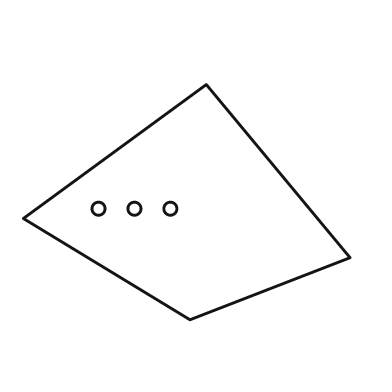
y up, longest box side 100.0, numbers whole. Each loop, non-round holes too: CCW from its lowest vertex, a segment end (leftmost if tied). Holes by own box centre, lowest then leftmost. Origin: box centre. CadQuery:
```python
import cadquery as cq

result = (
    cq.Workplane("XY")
    .moveTo(1.0, -36.0)
    .lineTo(50.0, -17.0)
    .lineTo(6.0, 36.0)
    .lineTo(-50.0, -5.0)
    .close()
    .moveTo(-27.0, -2.0)
    .circle(2.0)
    .moveTo(-16.0, -2.0)
    .circle(2.0)
    .moveTo(-5.0, -2.0)
    .circle(2.0)
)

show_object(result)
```